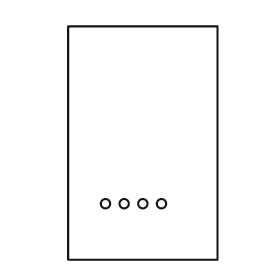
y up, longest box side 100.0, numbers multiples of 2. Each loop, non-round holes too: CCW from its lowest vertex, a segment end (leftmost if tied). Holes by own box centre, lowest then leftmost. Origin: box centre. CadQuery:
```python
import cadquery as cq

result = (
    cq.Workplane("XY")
    .moveTo(-32.0, -50.0)
    .lineTo(32.0, -50.0)
    .lineTo(32.0, 50.0)
    .lineTo(-32.0, 50.0)
    .close()
    .moveTo(-16.0, -26.0)
    .circle(2.0)
    .moveTo(-8.0, -26.0)
    .circle(2.0)
    .moveTo(0.0, -26.0)
    .circle(2.0)
    .moveTo(8.0, -26.0)
    .circle(2.0)
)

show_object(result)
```